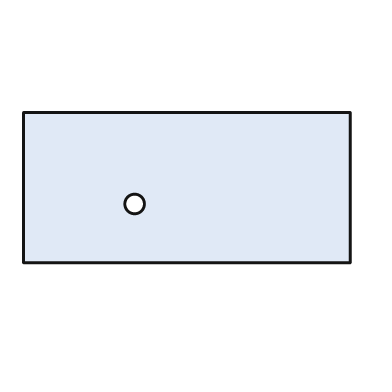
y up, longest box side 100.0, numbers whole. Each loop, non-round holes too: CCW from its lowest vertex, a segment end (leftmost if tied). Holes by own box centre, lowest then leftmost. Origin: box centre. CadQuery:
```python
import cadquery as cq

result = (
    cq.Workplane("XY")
    .moveTo(-50.0, -23.0)
    .lineTo(50.0, -23.0)
    .lineTo(50.0, 23.0)
    .lineTo(-50.0, 23.0)
    .close()
    .moveTo(-16.0, -5.0)
    .circle(3.0)
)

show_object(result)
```